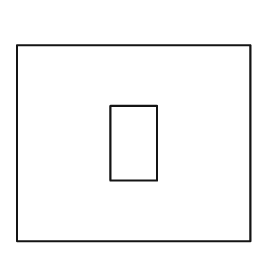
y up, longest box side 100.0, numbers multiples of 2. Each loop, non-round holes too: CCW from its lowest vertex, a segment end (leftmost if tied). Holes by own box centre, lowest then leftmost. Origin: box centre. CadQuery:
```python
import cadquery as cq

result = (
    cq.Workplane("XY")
    .moveTo(-50.0, -42.0)
    .lineTo(50.0, -42.0)
    .lineTo(50.0, 42.0)
    .lineTo(-50.0, 42.0)
    .close()
    .moveTo(-10.0, -16.0)
    .lineTo(10.0, -16.0)
    .lineTo(10.0, 16.0)
    .lineTo(-10.0, 16.0)
    .close()
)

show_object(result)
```